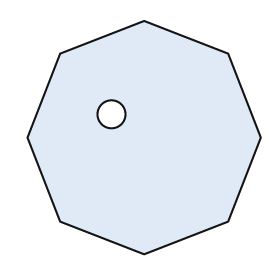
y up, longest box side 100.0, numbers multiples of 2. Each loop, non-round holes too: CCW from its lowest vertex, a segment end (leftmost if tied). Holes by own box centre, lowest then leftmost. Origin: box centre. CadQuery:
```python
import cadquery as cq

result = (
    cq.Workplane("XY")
    .moveTo(0.0, -50.0)
    .lineTo(36.0, -36.0)
    .lineTo(50.0, 0.0)
    .lineTo(36.0, 36.0)
    .lineTo(0.0, 50.0)
    .lineTo(-36.0, 36.0)
    .lineTo(-50.0, 0.0)
    .lineTo(-36.0, -36.0)
    .close()
    .moveTo(-14.0, 10.0)
    .circle(6.0)
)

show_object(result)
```